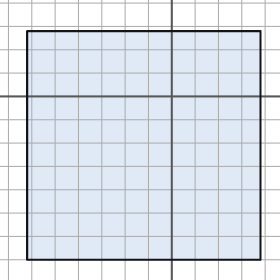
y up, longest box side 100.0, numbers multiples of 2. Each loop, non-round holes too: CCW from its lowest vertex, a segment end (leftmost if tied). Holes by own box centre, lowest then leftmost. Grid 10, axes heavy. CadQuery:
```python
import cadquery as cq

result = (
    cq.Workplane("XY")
    .moveTo(-62.0, -70.0)
    .lineTo(38.0, -70.0)
    .lineTo(38.0, 28.0)
    .lineTo(-62.0, 28.0)
    .close()
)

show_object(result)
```